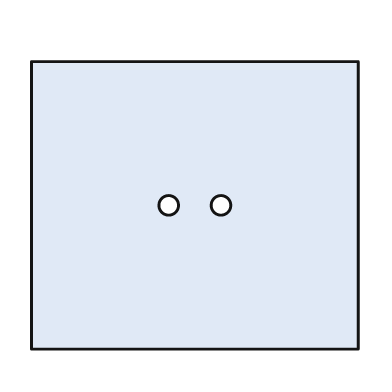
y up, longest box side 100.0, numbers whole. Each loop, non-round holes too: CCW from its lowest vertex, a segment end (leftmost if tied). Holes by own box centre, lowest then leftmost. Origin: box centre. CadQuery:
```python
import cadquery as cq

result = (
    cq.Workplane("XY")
    .moveTo(-50.0, -44.0)
    .lineTo(50.0, -44.0)
    .lineTo(50.0, 44.0)
    .lineTo(-50.0, 44.0)
    .close()
    .moveTo(-8.0, 0.0)
    .circle(3.0)
    .moveTo(8.0, 0.0)
    .circle(3.0)
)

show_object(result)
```